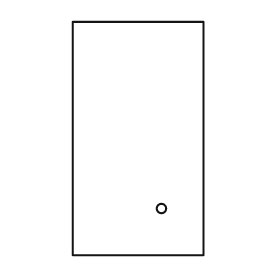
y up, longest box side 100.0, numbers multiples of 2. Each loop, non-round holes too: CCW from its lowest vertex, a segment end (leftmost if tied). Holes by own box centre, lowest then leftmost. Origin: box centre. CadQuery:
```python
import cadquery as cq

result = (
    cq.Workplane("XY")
    .moveTo(-28.0, -50.0)
    .lineTo(28.0, -50.0)
    .lineTo(28.0, 50.0)
    .lineTo(-28.0, 50.0)
    .close()
    .moveTo(10.0, -30.0)
    .circle(2.0)
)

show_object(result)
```